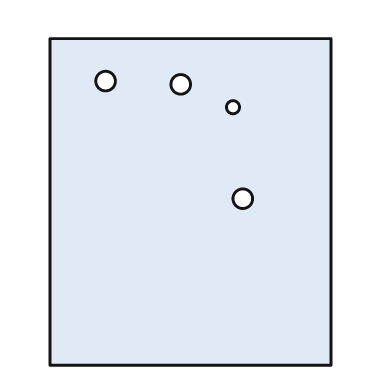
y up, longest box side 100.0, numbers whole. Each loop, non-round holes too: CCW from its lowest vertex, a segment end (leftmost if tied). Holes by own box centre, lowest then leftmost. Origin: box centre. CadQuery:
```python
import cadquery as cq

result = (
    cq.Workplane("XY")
    .moveTo(-43.0, -50.0)
    .lineTo(43.0, -50.0)
    .lineTo(43.0, 50.0)
    .lineTo(-43.0, 50.0)
    .close()
    .moveTo(16.0, 1.0)
    .circle(3.0)
    .moveTo(13.0, 29.0)
    .circle(2.0)
    .moveTo(-3.0, 36.0)
    .circle(3.0)
    .moveTo(-26.0, 37.0)
    .circle(3.0)
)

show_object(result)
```